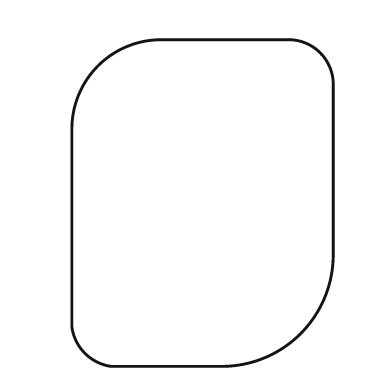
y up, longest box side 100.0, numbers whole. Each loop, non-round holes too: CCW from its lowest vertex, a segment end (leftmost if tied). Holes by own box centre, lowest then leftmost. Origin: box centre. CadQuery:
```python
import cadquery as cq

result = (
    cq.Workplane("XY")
    .moveTo(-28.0, -50.0)
    .lineTo(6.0, -50.0)
    .threePointArc((30.0, -40.0), (40.0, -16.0))
    .lineTo(40.0, 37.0)
    .threePointArc((36.0, 46.0), (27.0, 50.0))
    .lineTo(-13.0, 50.0)
    .threePointArc((-32.0, 42.0), (-40.0, 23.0))
    .lineTo(-40.0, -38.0)
    .threePointArc((-36.0, -46.0), (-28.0, -50.0))
    .close()
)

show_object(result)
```